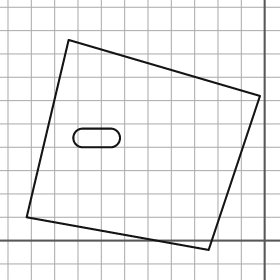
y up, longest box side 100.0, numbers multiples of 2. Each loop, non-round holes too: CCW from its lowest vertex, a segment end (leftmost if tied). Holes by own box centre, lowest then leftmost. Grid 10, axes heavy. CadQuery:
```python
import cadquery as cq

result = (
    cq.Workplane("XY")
    .moveTo(-24.0, -4.0)
    .lineTo(-2.0, 62.0)
    .lineTo(-84.0, 86.0)
    .lineTo(-102.0, 10.0)
    .close()
    .moveTo(-78.0, 40.0)
    .lineTo(-66.0, 40.0)
    .threePointArc((-62.0, 44.0), (-66.0, 48.0))
    .lineTo(-78.0, 48.0)
    .threePointArc((-82.0, 44.0), (-78.0, 40.0))
    .close()
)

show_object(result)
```